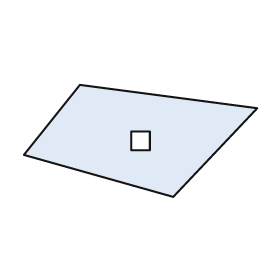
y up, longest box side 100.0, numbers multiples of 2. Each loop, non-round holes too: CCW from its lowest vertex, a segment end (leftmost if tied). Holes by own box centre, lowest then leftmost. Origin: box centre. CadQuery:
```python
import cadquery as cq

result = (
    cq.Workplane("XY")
    .moveTo(14.0, -24.0)
    .lineTo(50.0, 14.0)
    .lineTo(-26.0, 24.0)
    .lineTo(-50.0, -6.0)
    .close()
    .moveTo(-4.0, -4.0)
    .lineTo(4.0, -4.0)
    .lineTo(4.0, 4.0)
    .lineTo(-4.0, 4.0)
    .close()
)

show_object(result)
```